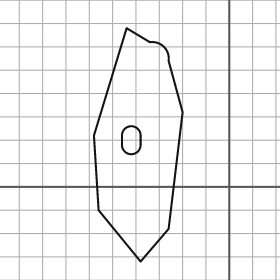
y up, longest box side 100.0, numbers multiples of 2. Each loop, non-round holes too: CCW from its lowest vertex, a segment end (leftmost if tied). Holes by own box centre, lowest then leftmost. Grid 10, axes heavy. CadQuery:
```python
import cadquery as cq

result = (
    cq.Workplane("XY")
    .moveTo(-38.0, -32.0)
    .lineTo(-26.0, -18.0)
    .lineTo(-20.0, 32.0)
    .lineTo(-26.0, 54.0)
    .threePointArc((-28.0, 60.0), (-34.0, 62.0))
    .lineTo(-44.0, 68.0)
    .lineTo(-58.0, 22.0)
    .lineTo(-56.0, -10.0)
    .close()
    .moveTo(-46.0, 18.0)
    .threePointArc((-42.0, 14.0), (-38.0, 18.0))
    .lineTo(-38.0, 22.0)
    .threePointArc((-42.0, 26.0), (-46.0, 22.0))
    .close()
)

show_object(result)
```